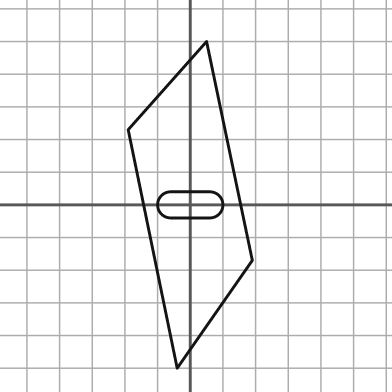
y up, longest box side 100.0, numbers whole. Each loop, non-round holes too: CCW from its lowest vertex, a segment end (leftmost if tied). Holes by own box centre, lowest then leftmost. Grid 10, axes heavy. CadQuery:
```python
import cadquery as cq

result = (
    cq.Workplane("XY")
    .moveTo(-4.0, -50.0)
    .lineTo(19.0, -17.0)
    .lineTo(5.0, 50.0)
    .lineTo(-19.0, 23.0)
    .close()
    .moveTo(-6.0, -4.0)
    .lineTo(6.0, -4.0)
    .threePointArc((10.0, 0.0), (6.0, 4.0))
    .lineTo(-6.0, 4.0)
    .threePointArc((-10.0, 0.0), (-6.0, -4.0))
    .close()
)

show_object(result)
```